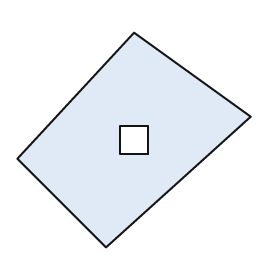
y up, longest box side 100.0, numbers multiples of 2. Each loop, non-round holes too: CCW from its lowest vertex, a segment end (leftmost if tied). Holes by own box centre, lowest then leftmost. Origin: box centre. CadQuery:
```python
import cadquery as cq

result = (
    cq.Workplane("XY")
    .moveTo(-12.0, -46.0)
    .lineTo(50.0, 10.0)
    .lineTo(0.0, 46.0)
    .lineTo(-50.0, -8.0)
    .close()
    .moveTo(-6.0, -6.0)
    .lineTo(6.0, -6.0)
    .lineTo(6.0, 6.0)
    .lineTo(-6.0, 6.0)
    .close()
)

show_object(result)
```